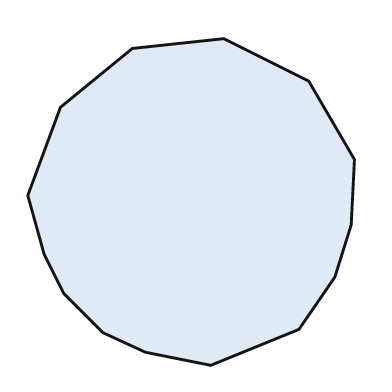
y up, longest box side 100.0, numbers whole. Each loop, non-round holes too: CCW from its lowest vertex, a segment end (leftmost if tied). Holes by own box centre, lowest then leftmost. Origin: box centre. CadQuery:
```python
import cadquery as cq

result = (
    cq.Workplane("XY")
    .moveTo(6.0, -50.0)
    .lineTo(33.0, -39.0)
    .lineTo(44.0, -23.0)
    .lineTo(49.0, -7.0)
    .lineTo(50.0, 13.0)
    .lineTo(36.0, 37.0)
    .lineTo(10.0, 50.0)
    .lineTo(-18.0, 47.0)
    .lineTo(-40.0, 29.0)
    .lineTo(-50.0, 2.0)
    .lineTo(-45.0, -16.0)
    .lineTo(-39.0, -28.0)
    .lineTo(-27.0, -40.0)
    .lineTo(-14.0, -46.0)
    .close()
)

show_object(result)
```